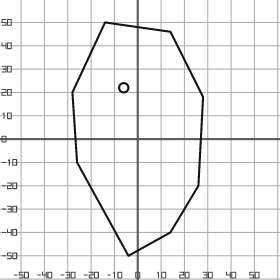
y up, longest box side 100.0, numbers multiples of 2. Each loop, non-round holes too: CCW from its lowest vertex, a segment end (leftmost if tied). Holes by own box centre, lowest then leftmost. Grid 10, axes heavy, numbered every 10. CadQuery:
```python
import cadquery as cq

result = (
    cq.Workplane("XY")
    .moveTo(-4.0, -50.0)
    .lineTo(14.0, -40.0)
    .lineTo(26.0, -20.0)
    .lineTo(28.0, 18.0)
    .lineTo(14.0, 46.0)
    .lineTo(-14.0, 50.0)
    .lineTo(-28.0, 20.0)
    .lineTo(-26.0, -10.0)
    .close()
    .moveTo(-6.0, 22.0)
    .circle(2.0)
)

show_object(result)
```